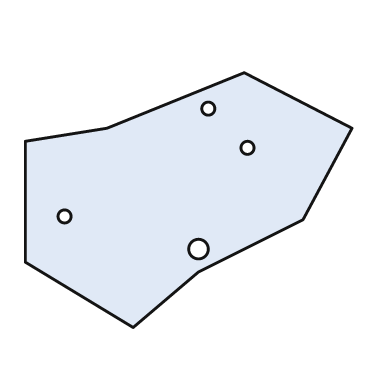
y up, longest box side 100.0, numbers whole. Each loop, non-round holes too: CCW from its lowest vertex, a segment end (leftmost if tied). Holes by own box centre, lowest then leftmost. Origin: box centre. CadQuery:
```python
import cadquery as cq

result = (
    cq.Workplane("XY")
    .moveTo(-17.0, -39.0)
    .lineTo(3.0, -22.0)
    .lineTo(35.0, -6.0)
    .lineTo(50.0, 22.0)
    .lineTo(17.0, 39.0)
    .lineTo(-25.0, 22.0)
    .lineTo(-50.0, 18.0)
    .lineTo(-50.0, -19.0)
    .close()
    .moveTo(3.0, -15.0)
    .circle(3.0)
    .moveTo(-38.0, -5.0)
    .circle(2.0)
    .moveTo(18.0, 16.0)
    .circle(2.0)
    .moveTo(6.0, 28.0)
    .circle(2.0)
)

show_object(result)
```